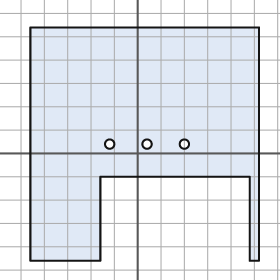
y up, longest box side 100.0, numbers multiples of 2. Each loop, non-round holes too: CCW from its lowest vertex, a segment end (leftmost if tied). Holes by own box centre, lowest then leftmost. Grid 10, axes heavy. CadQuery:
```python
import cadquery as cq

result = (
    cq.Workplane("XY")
    .moveTo(-46.0, -46.0)
    .lineTo(-16.0, -46.0)
    .lineTo(-16.0, -10.0)
    .lineTo(48.0, -10.0)
    .lineTo(48.0, -46.0)
    .lineTo(52.0, -46.0)
    .lineTo(52.0, 54.0)
    .lineTo(-46.0, 54.0)
    .close()
    .moveTo(-12.0, 4.0)
    .circle(2.0)
    .moveTo(4.0, 4.0)
    .circle(2.0)
    .moveTo(20.0, 4.0)
    .circle(2.0)
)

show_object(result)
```